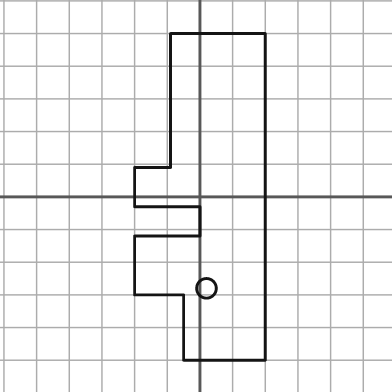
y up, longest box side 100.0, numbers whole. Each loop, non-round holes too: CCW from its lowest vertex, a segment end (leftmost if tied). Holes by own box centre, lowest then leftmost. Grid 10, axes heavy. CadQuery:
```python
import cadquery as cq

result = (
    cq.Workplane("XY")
    .moveTo(-5.0, -50.0)
    .lineTo(20.0, -50.0)
    .lineTo(20.0, 50.0)
    .lineTo(-9.0, 50.0)
    .lineTo(-9.0, 9.0)
    .lineTo(-20.0, 9.0)
    .lineTo(-20.0, -3.0)
    .lineTo(0.0, -3.0)
    .lineTo(0.0, -12.0)
    .lineTo(-20.0, -12.0)
    .lineTo(-20.0, -30.0)
    .lineTo(-5.0, -30.0)
    .close()
    .moveTo(2.0, -28.0)
    .circle(3.0)
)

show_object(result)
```